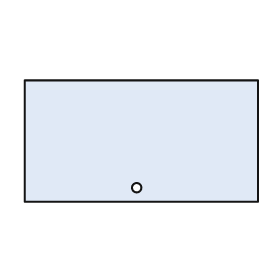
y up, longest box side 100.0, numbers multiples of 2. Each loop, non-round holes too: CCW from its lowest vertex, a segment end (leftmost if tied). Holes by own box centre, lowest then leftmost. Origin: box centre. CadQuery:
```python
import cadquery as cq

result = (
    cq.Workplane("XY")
    .moveTo(-50.0, -26.0)
    .lineTo(50.0, -26.0)
    .lineTo(50.0, 26.0)
    .lineTo(-50.0, 26.0)
    .close()
    .moveTo(-2.0, -20.0)
    .circle(2.0)
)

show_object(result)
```